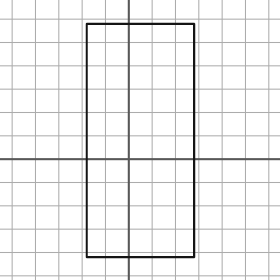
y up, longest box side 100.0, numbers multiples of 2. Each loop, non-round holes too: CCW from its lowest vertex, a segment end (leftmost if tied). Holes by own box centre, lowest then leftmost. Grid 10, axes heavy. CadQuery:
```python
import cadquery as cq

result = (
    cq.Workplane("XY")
    .moveTo(-18.0, -42.0)
    .lineTo(28.0, -42.0)
    .lineTo(28.0, 58.0)
    .lineTo(-18.0, 58.0)
    .close()
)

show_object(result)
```